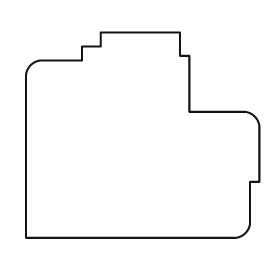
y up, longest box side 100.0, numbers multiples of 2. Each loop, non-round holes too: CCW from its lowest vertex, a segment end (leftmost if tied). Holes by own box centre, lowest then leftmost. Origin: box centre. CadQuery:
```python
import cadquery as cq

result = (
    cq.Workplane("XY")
    .moveTo(-50.0, -44.0)
    .lineTo(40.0, -44.0)
    .threePointArc((44.0, -42.0), (46.0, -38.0))
    .lineTo(46.0, -20.0)
    .lineTo(50.0, -20.0)
    .lineTo(50.0, 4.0)
    .threePointArc((48.0, 8.0), (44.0, 10.0))
    .lineTo(20.0, 10.0)
    .lineTo(20.0, 34.0)
    .lineTo(16.0, 34.0)
    .lineTo(16.0, 44.0)
    .lineTo(-18.0, 44.0)
    .lineTo(-18.0, 38.0)
    .lineTo(-26.0, 38.0)
    .lineTo(-26.0, 32.0)
    .lineTo(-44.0, 32.0)
    .threePointArc((-48.0, 30.0), (-50.0, 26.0))
    .close()
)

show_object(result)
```